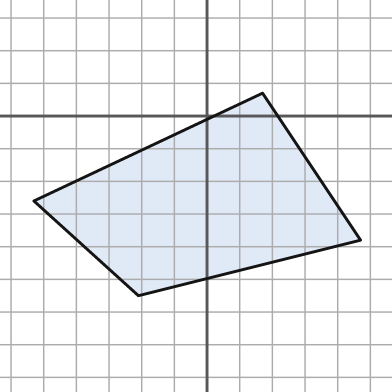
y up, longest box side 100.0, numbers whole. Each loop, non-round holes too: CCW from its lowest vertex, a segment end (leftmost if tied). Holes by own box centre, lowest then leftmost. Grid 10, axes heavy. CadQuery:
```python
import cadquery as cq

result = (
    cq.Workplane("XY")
    .moveTo(-21.0, -55.0)
    .lineTo(47.0, -38.0)
    .lineTo(17.0, 7.0)
    .lineTo(-53.0, -26.0)
    .close()
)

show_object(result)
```